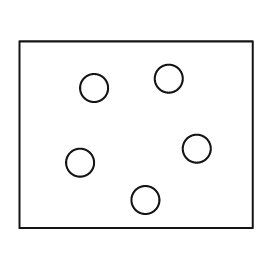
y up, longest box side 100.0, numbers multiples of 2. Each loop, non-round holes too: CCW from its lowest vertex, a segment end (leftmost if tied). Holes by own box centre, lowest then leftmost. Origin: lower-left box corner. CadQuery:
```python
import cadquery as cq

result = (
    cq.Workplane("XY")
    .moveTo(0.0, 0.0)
    .lineTo(100.0, 0.0)
    .lineTo(100.0, 80.0)
    .lineTo(0.0, 80.0)
    .close()
    .moveTo(54.0, 12.0)
    .circle(6.0)
    .moveTo(26.0, 28.0)
    .circle(6.0)
    .moveTo(76.0, 34.0)
    .circle(6.0)
    .moveTo(32.0, 60.0)
    .circle(6.0)
    .moveTo(64.0, 64.0)
    .circle(6.0)
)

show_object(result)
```